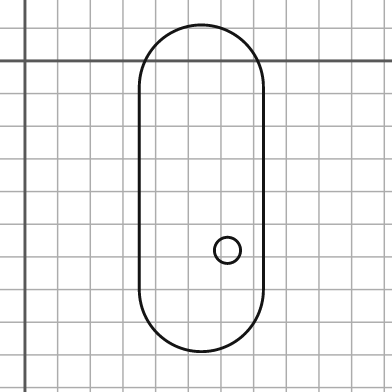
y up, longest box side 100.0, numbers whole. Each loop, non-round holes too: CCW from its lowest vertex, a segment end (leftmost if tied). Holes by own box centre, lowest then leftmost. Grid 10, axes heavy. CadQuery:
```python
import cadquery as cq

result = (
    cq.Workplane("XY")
    .moveTo(35.0, -70.0)
    .threePointArc((54.0, -89.0), (73.0, -70.0))
    .lineTo(73.0, -8.0)
    .threePointArc((54.0, 11.0), (35.0, -8.0))
    .close()
    .moveTo(62.0, -58.0)
    .circle(4.0)
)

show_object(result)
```